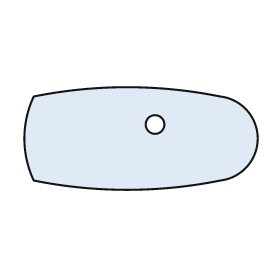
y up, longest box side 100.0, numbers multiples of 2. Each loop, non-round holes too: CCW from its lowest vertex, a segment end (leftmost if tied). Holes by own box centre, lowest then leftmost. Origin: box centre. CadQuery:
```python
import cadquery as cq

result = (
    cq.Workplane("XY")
    .moveTo(-46.0, -18.0)
    .threePointArc((-6.0, -22.0), (34.0, -18.0))
    .threePointArc((50.0, 0.0), (34.0, 18.0))
    .threePointArc((-6.0, 22.0), (-46.0, 18.0))
    .threePointArc((-50.0, 0.0), (-46.0, -18.0))
    .close()
    .moveTo(6.0, 6.0)
    .circle(4.0)
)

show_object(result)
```